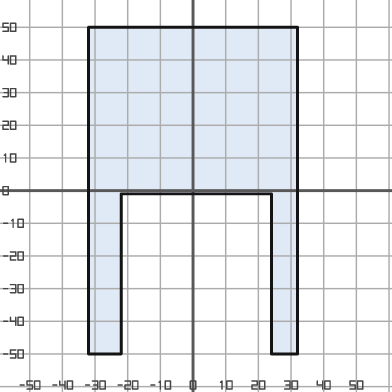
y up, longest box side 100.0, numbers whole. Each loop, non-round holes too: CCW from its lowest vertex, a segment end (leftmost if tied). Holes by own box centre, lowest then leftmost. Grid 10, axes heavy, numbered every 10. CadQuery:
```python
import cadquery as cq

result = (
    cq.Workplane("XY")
    .moveTo(-32.0, -50.0)
    .lineTo(-22.0, -50.0)
    .lineTo(-22.0, -1.0)
    .lineTo(24.0, -1.0)
    .lineTo(24.0, -50.0)
    .lineTo(32.0, -50.0)
    .lineTo(32.0, 50.0)
    .lineTo(-32.0, 50.0)
    .close()
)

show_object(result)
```